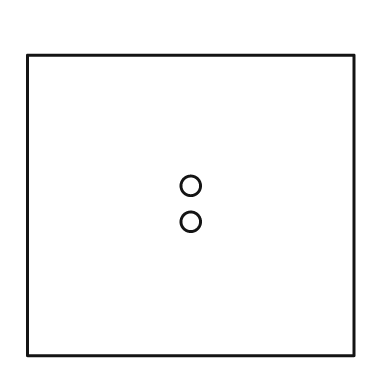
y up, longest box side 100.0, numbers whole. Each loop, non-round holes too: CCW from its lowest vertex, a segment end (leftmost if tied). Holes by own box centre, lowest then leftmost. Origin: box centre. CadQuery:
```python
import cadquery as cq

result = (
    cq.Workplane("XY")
    .moveTo(-50.0, -46.0)
    .lineTo(50.0, -46.0)
    .lineTo(50.0, 46.0)
    .lineTo(-50.0, 46.0)
    .close()
    .moveTo(0.0, -5.0)
    .circle(3.0)
    .moveTo(0.0, 6.0)
    .circle(3.0)
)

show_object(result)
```